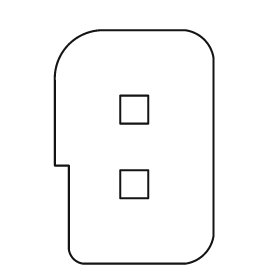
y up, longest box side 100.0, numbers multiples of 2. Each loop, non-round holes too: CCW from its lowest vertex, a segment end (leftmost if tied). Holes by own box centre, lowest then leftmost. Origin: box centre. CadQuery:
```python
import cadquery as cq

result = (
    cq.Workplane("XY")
    .moveTo(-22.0, -50.0)
    .lineTo(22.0, -50.0)
    .threePointArc((30.0, -46.0), (34.0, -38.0))
    .lineTo(34.0, 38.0)
    .threePointArc((30.0, 46.0), (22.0, 50.0))
    .lineTo(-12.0, 50.0)
    .threePointArc((-28.0, 44.0), (-34.0, 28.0))
    .lineTo(-34.0, -8.0)
    .lineTo(-28.0, -8.0)
    .lineTo(-28.0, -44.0)
    .threePointArc((-26.0, -48.0), (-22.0, -50.0))
    .close()
    .moveTo(-6.0, -22.0)
    .lineTo(6.0, -22.0)
    .lineTo(6.0, -10.0)
    .lineTo(-6.0, -10.0)
    .close()
    .moveTo(-6.0, 10.0)
    .lineTo(6.0, 10.0)
    .lineTo(6.0, 22.0)
    .lineTo(-6.0, 22.0)
    .close()
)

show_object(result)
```